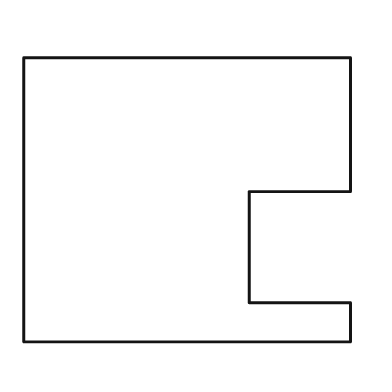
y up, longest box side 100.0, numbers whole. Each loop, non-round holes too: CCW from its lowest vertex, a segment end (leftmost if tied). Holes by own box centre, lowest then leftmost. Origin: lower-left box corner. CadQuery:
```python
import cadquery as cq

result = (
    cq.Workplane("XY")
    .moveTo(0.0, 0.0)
    .lineTo(100.0, 0.0)
    .lineTo(100.0, 12.0)
    .lineTo(69.0, 12.0)
    .lineTo(69.0, 46.0)
    .lineTo(100.0, 46.0)
    .lineTo(100.0, 87.0)
    .lineTo(0.0, 87.0)
    .close()
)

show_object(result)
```